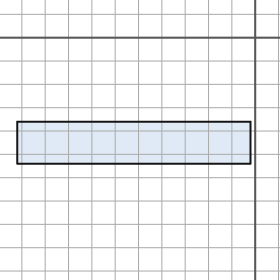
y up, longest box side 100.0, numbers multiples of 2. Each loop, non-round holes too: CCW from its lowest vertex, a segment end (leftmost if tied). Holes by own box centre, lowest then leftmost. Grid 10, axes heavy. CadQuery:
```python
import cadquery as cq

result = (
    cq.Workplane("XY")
    .moveTo(-102.0, -54.0)
    .lineTo(-2.0, -54.0)
    .lineTo(-2.0, -36.0)
    .lineTo(-102.0, -36.0)
    .close()
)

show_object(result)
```